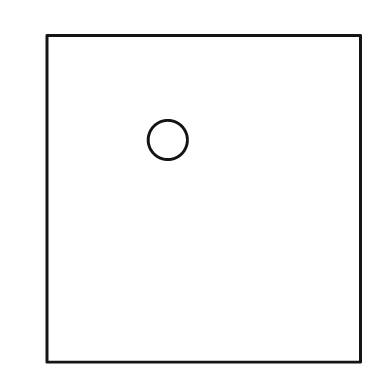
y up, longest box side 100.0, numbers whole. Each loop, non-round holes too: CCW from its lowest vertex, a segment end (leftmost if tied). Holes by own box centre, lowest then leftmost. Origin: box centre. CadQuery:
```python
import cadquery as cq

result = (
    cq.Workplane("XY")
    .moveTo(-48.0, -50.0)
    .lineTo(48.0, -50.0)
    .lineTo(48.0, 50.0)
    .lineTo(-48.0, 50.0)
    .close()
    .moveTo(-11.0, 18.0)
    .circle(6.0)
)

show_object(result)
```